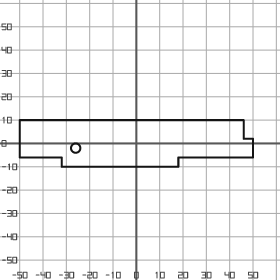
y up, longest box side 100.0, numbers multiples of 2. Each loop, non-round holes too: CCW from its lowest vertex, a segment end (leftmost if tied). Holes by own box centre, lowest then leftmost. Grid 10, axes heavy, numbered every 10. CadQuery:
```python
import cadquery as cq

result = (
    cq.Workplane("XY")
    .moveTo(-32.0, -10.0)
    .lineTo(18.0, -10.0)
    .lineTo(18.0, -6.0)
    .lineTo(50.0, -6.0)
    .lineTo(50.0, 2.0)
    .lineTo(46.0, 2.0)
    .lineTo(46.0, 10.0)
    .lineTo(-50.0, 10.0)
    .lineTo(-50.0, -6.0)
    .lineTo(-32.0, -6.0)
    .close()
    .moveTo(-26.0, -2.0)
    .circle(2.0)
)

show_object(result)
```